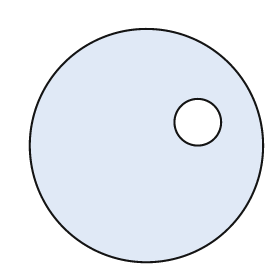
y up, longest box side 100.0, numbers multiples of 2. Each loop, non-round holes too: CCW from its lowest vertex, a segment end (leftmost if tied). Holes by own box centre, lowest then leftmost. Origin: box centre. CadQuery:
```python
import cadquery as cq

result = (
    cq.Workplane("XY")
    .moveTo(0.0, 0.0)
    .circle(50.0)
    .moveTo(22.0, 10.0)
    .circle(10.0)
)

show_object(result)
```